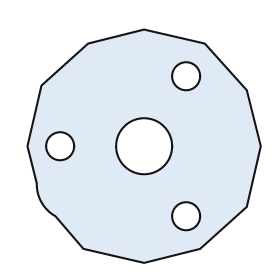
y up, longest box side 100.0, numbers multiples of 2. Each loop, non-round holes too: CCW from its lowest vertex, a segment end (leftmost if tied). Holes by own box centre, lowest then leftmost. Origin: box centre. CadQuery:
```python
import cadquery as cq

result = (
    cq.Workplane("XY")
    .moveTo(0.0, -50.0)
    .lineTo(24.0, -44.0)
    .lineTo(44.0, -26.0)
    .lineTo(50.0, 0.0)
    .lineTo(44.0, 24.0)
    .lineTo(26.0, 44.0)
    .lineTo(0.0, 50.0)
    .lineTo(-24.0, 44.0)
    .lineTo(-44.0, 26.0)
    .lineTo(-50.0, 0.0)
    .lineTo(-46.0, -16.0)
    .threePointArc((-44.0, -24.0), (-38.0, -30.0))
    .lineTo(-26.0, -44.0)
    .close()
    .moveTo(18.0, -30.0)
    .circle(6.0)
    .moveTo(-36.0, 0.0)
    .circle(6.0)
    .moveTo(0.0, 0.0)
    .circle(12.0)
    .moveTo(18.0, 30.0)
    .circle(6.0)
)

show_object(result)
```